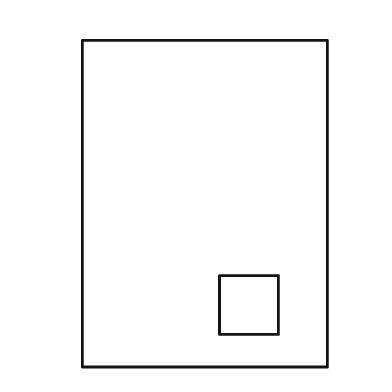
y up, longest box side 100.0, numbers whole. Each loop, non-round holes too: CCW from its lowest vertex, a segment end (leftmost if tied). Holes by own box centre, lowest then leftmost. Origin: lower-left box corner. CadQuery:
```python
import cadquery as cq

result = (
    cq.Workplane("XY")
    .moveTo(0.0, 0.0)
    .lineTo(75.0, 0.0)
    .lineTo(75.0, 100.0)
    .lineTo(0.0, 100.0)
    .close()
    .moveTo(42.0, 10.0)
    .lineTo(60.0, 10.0)
    .lineTo(60.0, 28.0)
    .lineTo(42.0, 28.0)
    .close()
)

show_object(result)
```